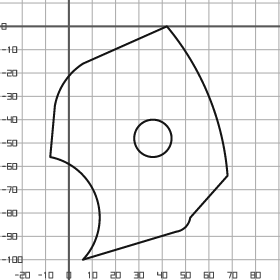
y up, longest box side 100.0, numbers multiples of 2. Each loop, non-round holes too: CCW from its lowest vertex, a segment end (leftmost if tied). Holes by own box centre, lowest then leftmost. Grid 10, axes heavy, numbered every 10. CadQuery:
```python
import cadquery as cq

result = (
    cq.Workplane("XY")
    .moveTo(6.0, -100.0)
    .lineTo(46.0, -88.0)
    .threePointArc((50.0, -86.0), (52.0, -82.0))
    .lineTo(68.0, -64.0)
    .threePointArc((60.0, -30.0), (42.0, 0.0))
    .lineTo(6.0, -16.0)
    .threePointArc((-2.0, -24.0), (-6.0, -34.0))
    .lineTo(-8.0, -56.0)
    .threePointArc((12.0, -74.0), (6.0, -100.0))
    .close()
    .moveTo(36.0, -48.0)
    .circle(8.0)
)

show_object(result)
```